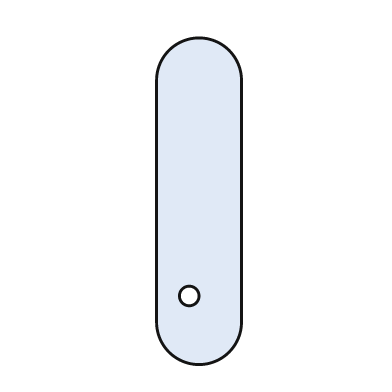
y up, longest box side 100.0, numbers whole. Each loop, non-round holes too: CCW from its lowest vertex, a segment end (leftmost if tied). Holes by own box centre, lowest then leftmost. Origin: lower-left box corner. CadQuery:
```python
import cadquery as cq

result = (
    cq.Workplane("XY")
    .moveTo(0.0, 13.0)
    .threePointArc((13.0, 0.0), (26.0, 13.0))
    .lineTo(26.0, 87.0)
    .threePointArc((13.0, 100.0), (0.0, 87.0))
    .close()
    .moveTo(10.0, 21.0)
    .circle(3.0)
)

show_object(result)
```